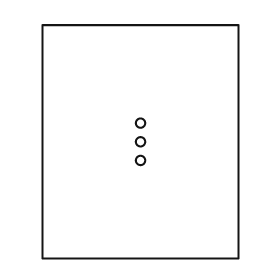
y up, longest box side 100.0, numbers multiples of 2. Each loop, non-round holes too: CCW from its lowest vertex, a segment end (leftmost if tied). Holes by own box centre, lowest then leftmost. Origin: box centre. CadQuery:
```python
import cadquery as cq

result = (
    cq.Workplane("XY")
    .moveTo(-42.0, -50.0)
    .lineTo(42.0, -50.0)
    .lineTo(42.0, 50.0)
    .lineTo(-42.0, 50.0)
    .close()
    .moveTo(0.0, -8.0)
    .circle(2.0)
    .moveTo(0.0, 0.0)
    .circle(2.0)
    .moveTo(0.0, 8.0)
    .circle(2.0)
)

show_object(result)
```